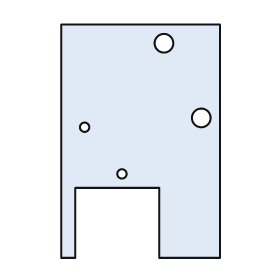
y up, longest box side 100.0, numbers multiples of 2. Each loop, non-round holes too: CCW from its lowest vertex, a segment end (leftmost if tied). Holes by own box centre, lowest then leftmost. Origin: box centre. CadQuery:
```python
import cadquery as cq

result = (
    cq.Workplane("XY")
    .moveTo(-34.0, -50.0)
    .lineTo(-28.0, -50.0)
    .lineTo(-28.0, -20.0)
    .lineTo(8.0, -20.0)
    .lineTo(8.0, -50.0)
    .lineTo(34.0, -50.0)
    .lineTo(34.0, 50.0)
    .lineTo(-34.0, 50.0)
    .close()
    .moveTo(-8.0, -14.0)
    .circle(2.0)
    .moveTo(-24.0, 6.0)
    .circle(2.0)
    .moveTo(26.0, 10.0)
    .circle(4.0)
    .moveTo(10.0, 42.0)
    .circle(4.0)
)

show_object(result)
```